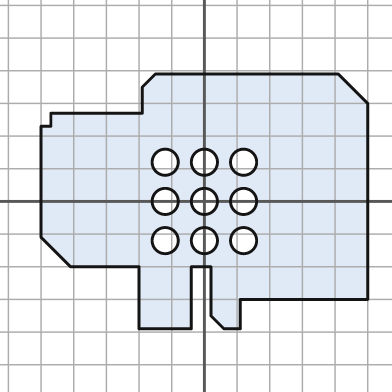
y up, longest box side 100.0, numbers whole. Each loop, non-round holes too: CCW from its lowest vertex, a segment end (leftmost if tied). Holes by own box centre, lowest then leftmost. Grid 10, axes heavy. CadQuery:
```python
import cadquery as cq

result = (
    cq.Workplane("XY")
    .moveTo(-20.0, -39.0)
    .lineTo(-4.0, -39.0)
    .lineTo(-4.0, -20.0)
    .lineTo(2.0, -20.0)
    .lineTo(2.0, -35.0)
    .lineTo(6.0, -39.0)
    .lineTo(11.0, -39.0)
    .lineTo(11.0, -30.0)
    .lineTo(50.0, -30.0)
    .lineTo(50.0, 30.0)
    .lineTo(41.0, 39.0)
    .lineTo(-15.0, 39.0)
    .lineTo(-19.0, 35.0)
    .lineTo(-19.0, 27.0)
    .lineTo(-47.0, 27.0)
    .lineTo(-47.0, 23.0)
    .lineTo(-50.0, 23.0)
    .lineTo(-50.0, -11.0)
    .lineTo(-41.0, -20.0)
    .lineTo(-20.0, -20.0)
    .close()
    .moveTo(-12.0, -12.0)
    .circle(4.0)
    .moveTo(0.0, -12.0)
    .circle(4.0)
    .moveTo(12.0, -12.0)
    .circle(4.0)
    .moveTo(-12.0, 0.0)
    .circle(4.0)
    .moveTo(0.0, 0.0)
    .circle(4.0)
    .moveTo(12.0, 0.0)
    .circle(4.0)
    .moveTo(-12.0, 12.0)
    .circle(4.0)
    .moveTo(0.0, 12.0)
    .circle(4.0)
    .moveTo(12.0, 12.0)
    .circle(4.0)
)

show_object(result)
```